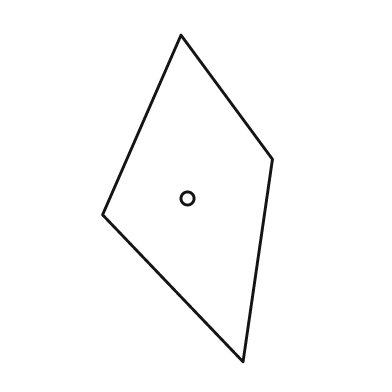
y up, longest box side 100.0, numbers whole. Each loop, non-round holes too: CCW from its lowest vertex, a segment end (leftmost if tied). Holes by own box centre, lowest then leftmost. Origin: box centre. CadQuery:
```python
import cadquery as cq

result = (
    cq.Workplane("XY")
    .moveTo(17.0, -50.0)
    .lineTo(26.0, 12.0)
    .lineTo(-2.0, 50.0)
    .lineTo(-26.0, -5.0)
    .close()
    .moveTo(0.0, 0.0)
    .circle(2.0)
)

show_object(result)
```